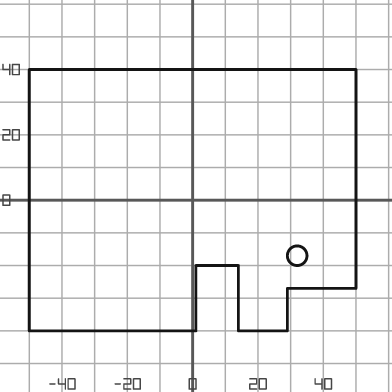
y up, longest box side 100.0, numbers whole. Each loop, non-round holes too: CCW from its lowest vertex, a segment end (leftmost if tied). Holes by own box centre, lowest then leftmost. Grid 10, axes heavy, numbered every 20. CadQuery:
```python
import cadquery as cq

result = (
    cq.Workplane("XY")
    .moveTo(-50.0, -40.0)
    .lineTo(1.0, -40.0)
    .lineTo(1.0, -20.0)
    .lineTo(14.0, -20.0)
    .lineTo(14.0, -40.0)
    .lineTo(29.0, -40.0)
    .lineTo(29.0, -27.0)
    .lineTo(50.0, -27.0)
    .lineTo(50.0, 40.0)
    .lineTo(-50.0, 40.0)
    .close()
    .moveTo(32.0, -17.0)
    .circle(3.0)
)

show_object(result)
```